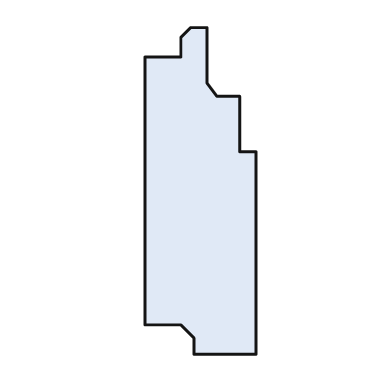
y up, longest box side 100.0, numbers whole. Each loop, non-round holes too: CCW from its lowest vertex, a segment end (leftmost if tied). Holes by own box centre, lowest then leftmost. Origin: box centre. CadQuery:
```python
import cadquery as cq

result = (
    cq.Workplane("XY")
    .moveTo(-2.0, -50.0)
    .lineTo(17.0, -50.0)
    .lineTo(17.0, 12.0)
    .lineTo(12.0, 12.0)
    .lineTo(12.0, 29.0)
    .lineTo(5.0, 29.0)
    .lineTo(2.0, 33.0)
    .lineTo(2.0, 50.0)
    .lineTo(-3.0, 50.0)
    .lineTo(-6.0, 47.0)
    .lineTo(-6.0, 41.0)
    .lineTo(-17.0, 41.0)
    .lineTo(-17.0, -41.0)
    .lineTo(-6.0, -41.0)
    .lineTo(-2.0, -45.0)
    .close()
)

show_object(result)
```